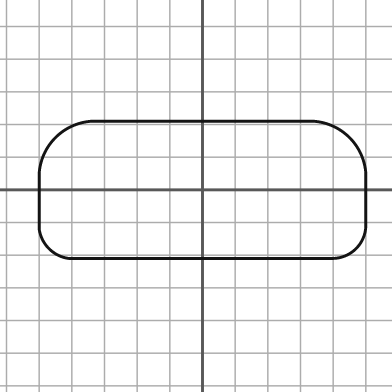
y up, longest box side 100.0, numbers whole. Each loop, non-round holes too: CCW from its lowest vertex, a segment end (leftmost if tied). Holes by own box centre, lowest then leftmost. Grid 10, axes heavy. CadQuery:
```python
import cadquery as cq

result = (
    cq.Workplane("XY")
    .moveTo(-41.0, -21.0)
    .lineTo(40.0, -21.0)
    .threePointArc((47.0, -18.0), (50.0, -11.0))
    .lineTo(50.0, 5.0)
    .threePointArc((45.0, 16.0), (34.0, 21.0))
    .lineTo(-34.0, 21.0)
    .threePointArc((-45.0, 16.0), (-50.0, 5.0))
    .lineTo(-50.0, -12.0)
    .threePointArc((-47.0, -18.0), (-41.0, -21.0))
    .close()
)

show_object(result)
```